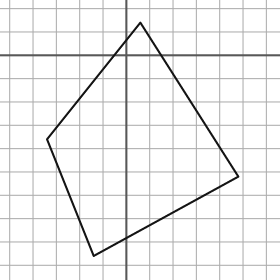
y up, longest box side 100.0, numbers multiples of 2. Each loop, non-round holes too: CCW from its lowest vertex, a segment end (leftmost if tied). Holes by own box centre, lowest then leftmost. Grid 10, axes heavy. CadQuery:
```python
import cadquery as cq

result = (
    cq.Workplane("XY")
    .moveTo(-14.0, -86.0)
    .lineTo(48.0, -52.0)
    .lineTo(6.0, 14.0)
    .lineTo(-34.0, -36.0)
    .close()
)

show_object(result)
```